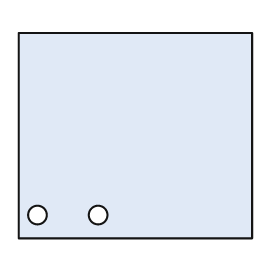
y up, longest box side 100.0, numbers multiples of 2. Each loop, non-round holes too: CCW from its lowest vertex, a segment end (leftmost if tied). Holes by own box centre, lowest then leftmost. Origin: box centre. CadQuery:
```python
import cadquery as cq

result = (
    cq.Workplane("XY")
    .moveTo(-50.0, -44.0)
    .lineTo(50.0, -44.0)
    .lineTo(50.0, 44.0)
    .lineTo(-50.0, 44.0)
    .close()
    .moveTo(-42.0, -34.0)
    .circle(4.0)
    .moveTo(-16.0, -34.0)
    .circle(4.0)
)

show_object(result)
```